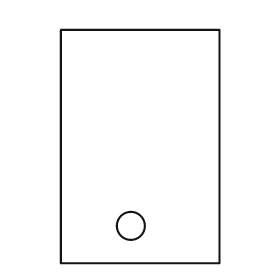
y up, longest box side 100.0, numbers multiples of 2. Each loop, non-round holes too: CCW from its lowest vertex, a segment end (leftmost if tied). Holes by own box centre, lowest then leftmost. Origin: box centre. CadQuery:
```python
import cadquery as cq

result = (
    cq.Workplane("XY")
    .moveTo(-34.0, -50.0)
    .lineTo(34.0, -50.0)
    .lineTo(34.0, 50.0)
    .lineTo(-34.0, 50.0)
    .close()
    .moveTo(-4.0, -34.0)
    .circle(6.0)
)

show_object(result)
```